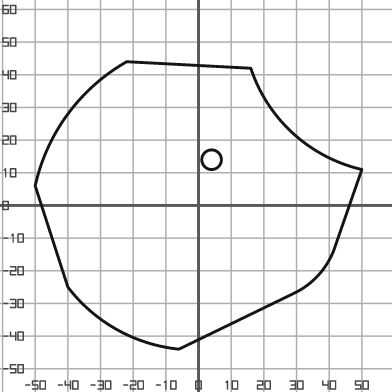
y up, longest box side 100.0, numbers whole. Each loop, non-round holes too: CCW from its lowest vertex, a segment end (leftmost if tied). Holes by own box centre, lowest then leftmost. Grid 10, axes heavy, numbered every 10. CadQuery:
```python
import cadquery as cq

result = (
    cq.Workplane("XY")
    .moveTo(-6.0, -44.0)
    .lineTo(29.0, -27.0)
    .threePointArc((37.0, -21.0), (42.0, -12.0))
    .lineTo(50.0, 11.0)
    .threePointArc((29.0, 22.0), (16.0, 42.0))
    .lineTo(-22.0, 44.0)
    .threePointArc((-40.0, 28.0), (-50.0, 6.0))
    .lineTo(-40.0, -25.0)
    .threePointArc((-25.0, -38.0), (-6.0, -44.0))
    .close()
    .moveTo(4.0, 14.0)
    .circle(3.0)
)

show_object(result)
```